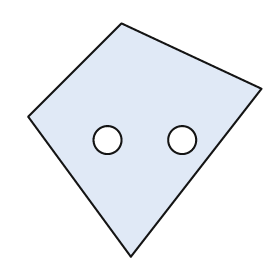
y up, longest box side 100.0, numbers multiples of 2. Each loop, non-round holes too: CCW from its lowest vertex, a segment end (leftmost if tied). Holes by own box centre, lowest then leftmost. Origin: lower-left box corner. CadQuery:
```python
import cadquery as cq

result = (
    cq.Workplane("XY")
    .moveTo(44.0, 0.0)
    .lineTo(100.0, 72.0)
    .lineTo(40.0, 100.0)
    .lineTo(0.0, 60.0)
    .close()
    .moveTo(34.0, 50.0)
    .circle(6.0)
    .moveTo(66.0, 50.0)
    .circle(6.0)
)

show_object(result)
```